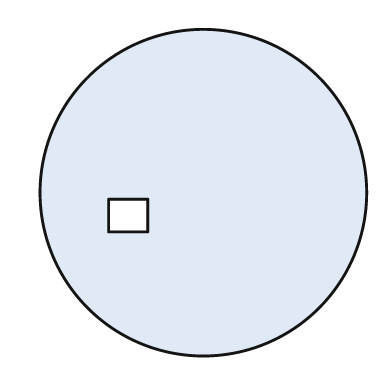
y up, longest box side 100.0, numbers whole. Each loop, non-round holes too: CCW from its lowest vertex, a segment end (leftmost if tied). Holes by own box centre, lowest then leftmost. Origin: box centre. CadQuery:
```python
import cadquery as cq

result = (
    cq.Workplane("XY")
    .moveTo(0.0, 0.0)
    .circle(50.0)
    .moveTo(-29.0, -12.0)
    .lineTo(-17.0, -12.0)
    .lineTo(-17.0, -2.0)
    .lineTo(-29.0, -2.0)
    .close()
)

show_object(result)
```